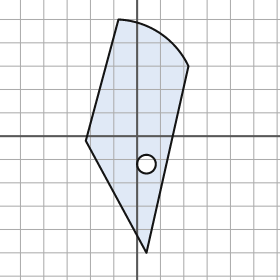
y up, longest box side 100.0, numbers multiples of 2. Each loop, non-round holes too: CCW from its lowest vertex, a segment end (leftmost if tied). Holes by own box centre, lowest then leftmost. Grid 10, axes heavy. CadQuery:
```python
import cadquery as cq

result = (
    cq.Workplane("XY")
    .moveTo(4.0, -50.0)
    .lineTo(22.0, 30.0)
    .threePointArc((10.0, 44.0), (-8.0, 50.0))
    .lineTo(-22.0, -2.0)
    .close()
    .moveTo(4.0, -12.0)
    .circle(4.0)
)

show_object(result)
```